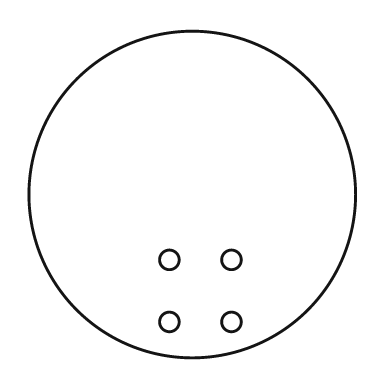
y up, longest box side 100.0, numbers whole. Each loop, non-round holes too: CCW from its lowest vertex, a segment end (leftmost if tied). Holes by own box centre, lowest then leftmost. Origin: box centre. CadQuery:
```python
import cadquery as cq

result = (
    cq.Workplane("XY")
    .moveTo(0.0, 0.0)
    .circle(50.0)
    .moveTo(-7.0, -39.0)
    .circle(3.0)
    .moveTo(12.0, -39.0)
    .circle(3.0)
    .moveTo(-7.0, -20.0)
    .circle(3.0)
    .moveTo(12.0, -20.0)
    .circle(3.0)
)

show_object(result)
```